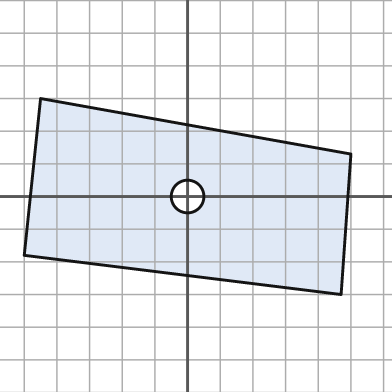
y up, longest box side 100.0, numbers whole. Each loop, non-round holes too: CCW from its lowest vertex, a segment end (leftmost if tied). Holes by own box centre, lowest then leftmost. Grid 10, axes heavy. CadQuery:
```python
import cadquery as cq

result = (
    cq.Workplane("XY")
    .moveTo(47.0, -30.0)
    .lineTo(50.0, 13.0)
    .lineTo(-45.0, 30.0)
    .lineTo(-50.0, -18.0)
    .close()
    .moveTo(0.0, 0.0)
    .circle(5.0)
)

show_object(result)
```